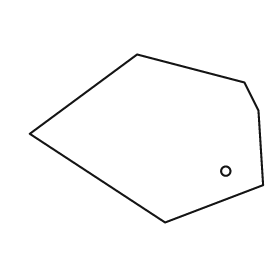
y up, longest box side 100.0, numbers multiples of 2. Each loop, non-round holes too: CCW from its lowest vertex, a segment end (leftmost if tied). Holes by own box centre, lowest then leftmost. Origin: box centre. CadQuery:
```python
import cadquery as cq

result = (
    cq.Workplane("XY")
    .moveTo(8.0, -36.0)
    .lineTo(50.0, -20.0)
    .lineTo(48.0, 12.0)
    .lineTo(42.0, 24.0)
    .lineTo(-4.0, 36.0)
    .lineTo(-50.0, 2.0)
    .close()
    .moveTo(34.0, -14.0)
    .circle(2.0)
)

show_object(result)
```